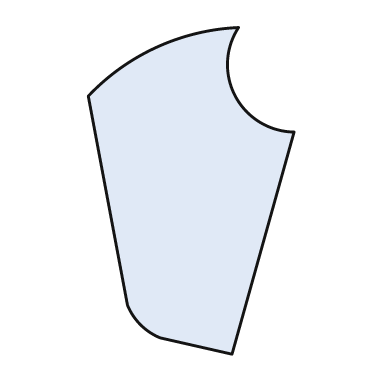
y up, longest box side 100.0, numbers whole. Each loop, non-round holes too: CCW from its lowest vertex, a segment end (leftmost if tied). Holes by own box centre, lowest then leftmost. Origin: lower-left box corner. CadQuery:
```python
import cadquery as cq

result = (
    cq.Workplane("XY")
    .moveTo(44.0, 0.0)
    .lineTo(63.0, 68.0)
    .threePointArc((45.0, 79.0), (46.0, 100.0))
    .threePointArc((21.0, 94.0), (0.0, 79.0))
    .lineTo(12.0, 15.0)
    .threePointArc((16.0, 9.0), (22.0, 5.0))
    .close()
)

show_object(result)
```